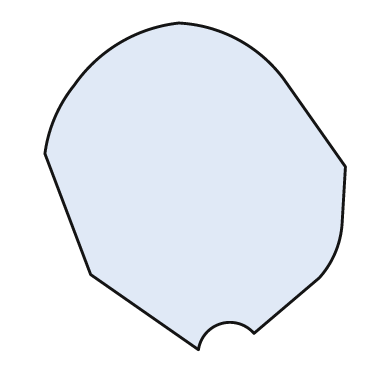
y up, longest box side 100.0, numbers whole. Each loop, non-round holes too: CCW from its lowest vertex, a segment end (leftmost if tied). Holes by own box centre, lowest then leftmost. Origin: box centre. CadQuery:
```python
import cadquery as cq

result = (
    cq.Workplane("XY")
    .moveTo(1.0, -50.0)
    .threePointArc((8.0, -42.0), (18.0, -45.0))
    .lineTo(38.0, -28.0)
    .threePointArc((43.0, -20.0), (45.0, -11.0))
    .lineTo(46.0, 6.0)
    .lineTo(27.0, 33.0)
    .threePointArc((13.0, 45.0), (-5.0, 50.0))
    .threePointArc((-23.0, 44.0), (-37.0, 31.0))
    .threePointArc((-43.0, 21.0), (-46.0, 10.0))
    .lineTo(-32.0, -27.0)
    .close()
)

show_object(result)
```